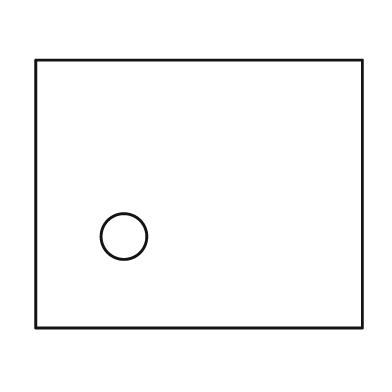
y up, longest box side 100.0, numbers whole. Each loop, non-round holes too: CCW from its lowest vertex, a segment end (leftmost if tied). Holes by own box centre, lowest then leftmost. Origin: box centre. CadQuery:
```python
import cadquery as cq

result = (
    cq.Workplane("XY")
    .moveTo(-50.0, -41.0)
    .lineTo(50.0, -41.0)
    .lineTo(50.0, 41.0)
    .lineTo(-50.0, 41.0)
    .close()
    .moveTo(-23.0, -13.0)
    .circle(7.0)
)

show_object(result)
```